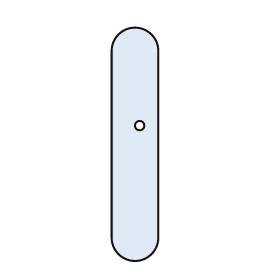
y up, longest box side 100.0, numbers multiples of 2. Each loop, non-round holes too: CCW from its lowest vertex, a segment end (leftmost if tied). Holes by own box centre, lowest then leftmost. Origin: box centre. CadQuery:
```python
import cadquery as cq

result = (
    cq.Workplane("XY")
    .moveTo(-10.0, -40.0)
    .threePointArc((0.0, -50.0), (10.0, -40.0))
    .lineTo(10.0, 40.0)
    .threePointArc((0.0, 50.0), (-10.0, 40.0))
    .close()
    .moveTo(2.0, 8.0)
    .circle(2.0)
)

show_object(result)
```